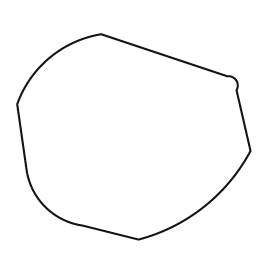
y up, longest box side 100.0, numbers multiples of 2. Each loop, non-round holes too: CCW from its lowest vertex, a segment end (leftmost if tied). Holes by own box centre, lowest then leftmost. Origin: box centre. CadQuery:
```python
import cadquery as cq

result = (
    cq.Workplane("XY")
    .moveTo(2.0, -44.0)
    .threePointArc((30.0, -30.0), (50.0, -6.0))
    .lineTo(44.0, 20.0)
    .threePointArc((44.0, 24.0), (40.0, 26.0))
    .lineTo(-14.0, 44.0)
    .threePointArc((-36.0, 34.0), (-50.0, 14.0))
    .lineTo(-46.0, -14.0)
    .threePointArc((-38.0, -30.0), (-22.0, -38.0))
    .close()
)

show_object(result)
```